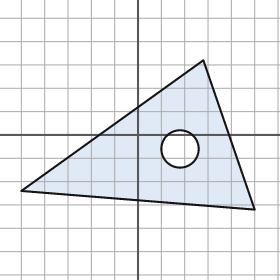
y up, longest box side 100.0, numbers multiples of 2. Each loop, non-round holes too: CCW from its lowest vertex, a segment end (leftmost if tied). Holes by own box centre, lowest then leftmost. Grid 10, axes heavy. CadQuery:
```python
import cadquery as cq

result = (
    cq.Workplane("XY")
    .moveTo(50.0, -32.0)
    .lineTo(28.0, 32.0)
    .lineTo(-50.0, -24.0)
    .close()
    .moveTo(18.0, -6.0)
    .circle(8.0)
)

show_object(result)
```